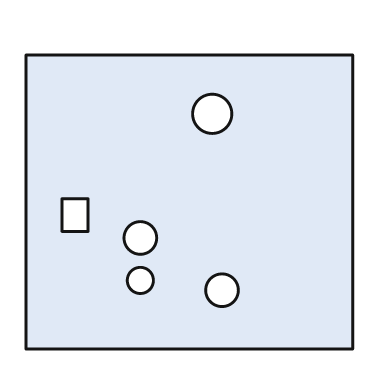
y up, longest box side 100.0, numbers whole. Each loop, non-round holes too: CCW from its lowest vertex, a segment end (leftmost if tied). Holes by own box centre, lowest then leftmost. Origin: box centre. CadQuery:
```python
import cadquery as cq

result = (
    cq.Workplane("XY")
    .moveTo(-50.0, -45.0)
    .lineTo(50.0, -45.0)
    .lineTo(50.0, 45.0)
    .lineTo(-50.0, 45.0)
    .close()
    .moveTo(10.0, -27.0)
    .circle(5.0)
    .moveTo(-15.0, -24.0)
    .circle(4.0)
    .moveTo(-15.0, -11.0)
    .circle(5.0)
    .moveTo(-39.0, -9.0)
    .lineTo(-31.0, -9.0)
    .lineTo(-31.0, 1.0)
    .lineTo(-39.0, 1.0)
    .close()
    .moveTo(7.0, 27.0)
    .circle(6.0)
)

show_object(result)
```